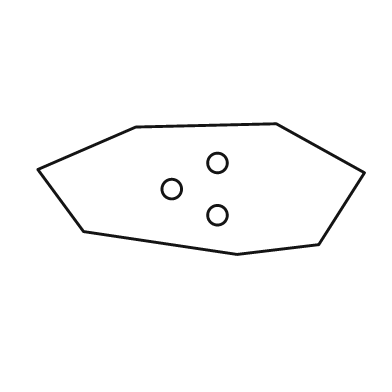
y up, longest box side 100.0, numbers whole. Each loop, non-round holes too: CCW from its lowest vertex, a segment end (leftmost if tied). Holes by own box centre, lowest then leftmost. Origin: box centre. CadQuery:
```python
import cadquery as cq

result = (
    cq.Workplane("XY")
    .moveTo(11.0, -20.0)
    .lineTo(36.0, -17.0)
    .lineTo(50.0, 5.0)
    .lineTo(23.0, 20.0)
    .lineTo(-20.0, 19.0)
    .lineTo(-50.0, 6.0)
    .lineTo(-36.0, -13.0)
    .close()
    .moveTo(5.0, -8.0)
    .circle(3.0)
    .moveTo(-9.0, 0.0)
    .circle(3.0)
    .moveTo(5.0, 8.0)
    .circle(3.0)
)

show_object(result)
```